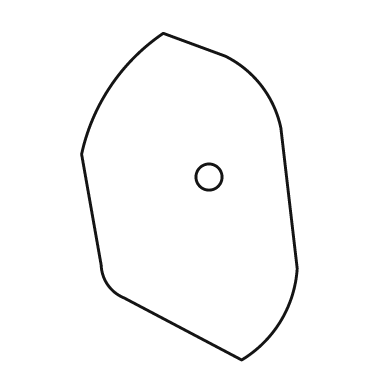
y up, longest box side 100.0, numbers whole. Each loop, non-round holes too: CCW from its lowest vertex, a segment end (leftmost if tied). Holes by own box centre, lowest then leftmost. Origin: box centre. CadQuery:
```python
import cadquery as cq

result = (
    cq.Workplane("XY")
    .moveTo(16.0, -50.0)
    .threePointArc((28.0, -38.0), (33.0, -22.0))
    .lineTo(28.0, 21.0)
    .threePointArc((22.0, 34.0), (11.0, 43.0))
    .lineTo(-8.0, 50.0)
    .threePointArc((-24.0, 34.0), (-33.0, 13.0))
    .lineTo(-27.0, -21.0)
    .threePointArc((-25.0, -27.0), (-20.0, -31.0))
    .close()
    .moveTo(6.0, 6.0)
    .circle(4.0)
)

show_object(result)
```